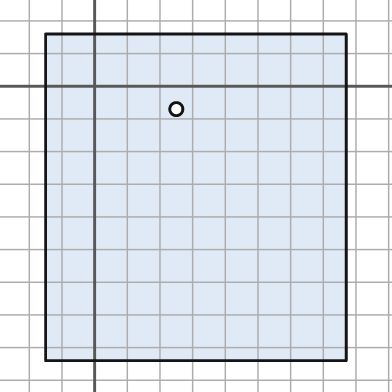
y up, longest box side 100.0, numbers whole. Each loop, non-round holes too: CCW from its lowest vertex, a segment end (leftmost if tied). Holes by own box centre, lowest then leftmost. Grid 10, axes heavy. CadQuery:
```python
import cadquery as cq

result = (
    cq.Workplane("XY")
    .moveTo(-15.0, -84.0)
    .lineTo(77.0, -84.0)
    .lineTo(77.0, 16.0)
    .lineTo(-15.0, 16.0)
    .close()
    .moveTo(25.0, -7.0)
    .circle(2.0)
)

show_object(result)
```